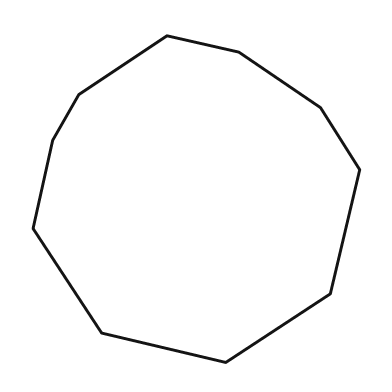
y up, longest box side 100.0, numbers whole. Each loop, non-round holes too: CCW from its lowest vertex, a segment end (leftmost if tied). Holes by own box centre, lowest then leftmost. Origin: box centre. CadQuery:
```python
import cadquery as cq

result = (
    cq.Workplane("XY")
    .moveTo(9.0, -50.0)
    .lineTo(41.0, -29.0)
    .lineTo(50.0, 9.0)
    .lineTo(38.0, 28.0)
    .lineTo(13.0, 45.0)
    .lineTo(-9.0, 50.0)
    .lineTo(-36.0, 32.0)
    .lineTo(-44.0, 18.0)
    .lineTo(-50.0, -9.0)
    .lineTo(-29.0, -41.0)
    .close()
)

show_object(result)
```